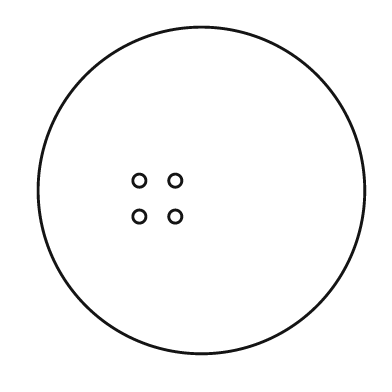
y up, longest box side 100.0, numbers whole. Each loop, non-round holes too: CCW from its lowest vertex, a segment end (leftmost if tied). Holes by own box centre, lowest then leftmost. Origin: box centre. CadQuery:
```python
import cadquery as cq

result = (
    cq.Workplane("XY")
    .moveTo(0.0, 0.0)
    .circle(50.0)
    .moveTo(-19.0, -8.0)
    .circle(2.0)
    .moveTo(-8.0, -8.0)
    .circle(2.0)
    .moveTo(-19.0, 3.0)
    .circle(2.0)
    .moveTo(-8.0, 3.0)
    .circle(2.0)
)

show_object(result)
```